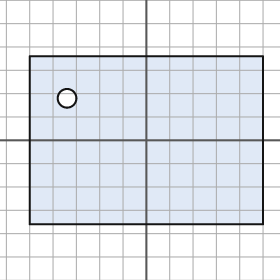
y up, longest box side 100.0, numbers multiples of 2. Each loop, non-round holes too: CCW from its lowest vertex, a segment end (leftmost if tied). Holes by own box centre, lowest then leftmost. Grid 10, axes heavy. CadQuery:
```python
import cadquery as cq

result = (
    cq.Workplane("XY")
    .moveTo(-50.0, -36.0)
    .lineTo(50.0, -36.0)
    .lineTo(50.0, 36.0)
    .lineTo(-50.0, 36.0)
    .close()
    .moveTo(-34.0, 18.0)
    .circle(4.0)
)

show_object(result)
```